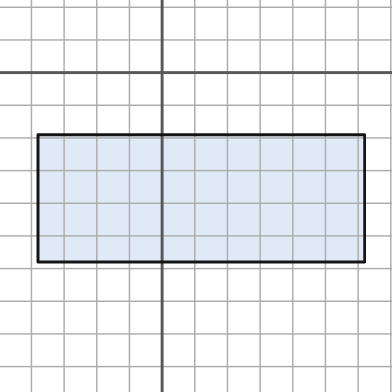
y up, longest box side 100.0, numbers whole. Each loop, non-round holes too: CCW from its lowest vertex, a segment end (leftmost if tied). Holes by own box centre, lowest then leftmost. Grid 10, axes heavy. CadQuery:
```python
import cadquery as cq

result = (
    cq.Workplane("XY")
    .moveTo(-38.0, -58.0)
    .lineTo(62.0, -58.0)
    .lineTo(62.0, -19.0)
    .lineTo(-38.0, -19.0)
    .close()
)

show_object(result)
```